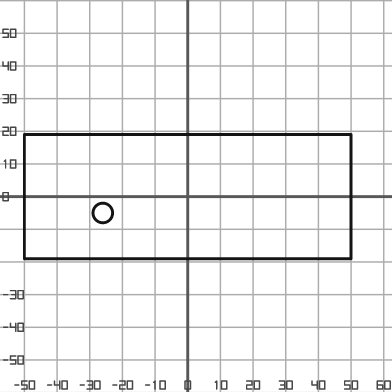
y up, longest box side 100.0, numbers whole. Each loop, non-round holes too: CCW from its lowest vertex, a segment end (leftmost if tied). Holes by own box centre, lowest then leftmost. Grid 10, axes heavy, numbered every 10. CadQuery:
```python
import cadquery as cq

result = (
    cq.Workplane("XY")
    .moveTo(-50.0, -19.0)
    .lineTo(50.0, -19.0)
    .lineTo(50.0, 19.0)
    .lineTo(-50.0, 19.0)
    .close()
    .moveTo(-26.0, -5.0)
    .circle(3.0)
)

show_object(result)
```